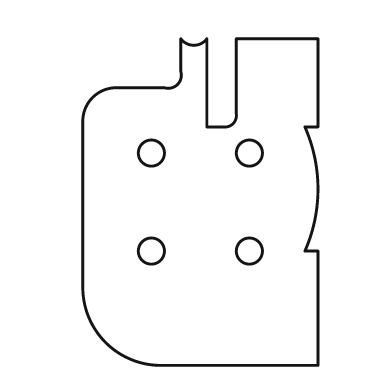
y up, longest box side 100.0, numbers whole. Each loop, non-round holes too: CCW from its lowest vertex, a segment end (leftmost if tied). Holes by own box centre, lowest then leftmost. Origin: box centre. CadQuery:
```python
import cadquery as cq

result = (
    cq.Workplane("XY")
    .moveTo(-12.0, -50.0)
    .lineTo(36.0, -50.0)
    .lineTo(36.0, -15.0)
    .lineTo(32.0, -15.0)
    .threePointArc((36.0, 4.0), (32.0, 23.0))
    .lineTo(36.0, 23.0)
    .lineTo(36.0, 50.0)
    .lineTo(11.0, 50.0)
    .lineTo(11.0, 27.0)
    .threePointArc((10.0, 24.0), (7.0, 23.0))
    .lineTo(2.0, 23.0)
    .lineTo(2.0, 50.0)
    .threePointArc((-2.0, 48.0), (-6.0, 50.0))
    .lineTo(-6.0, 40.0)
    .threePointArc((-7.0, 36.0), (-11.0, 35.0))
    .lineTo(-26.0, 35.0)
    .threePointArc((-33.0, 32.0), (-36.0, 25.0))
    .lineTo(-36.0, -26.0)
    .threePointArc((-29.0, -43.0), (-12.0, -50.0))
    .close()
    .moveTo(-15.0, -15.0)
    .circle(4.0)
    .moveTo(15.0, -15.0)
    .circle(4.0)
    .moveTo(-15.0, 15.0)
    .circle(4.0)
    .moveTo(15.0, 15.0)
    .circle(4.0)
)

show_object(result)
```